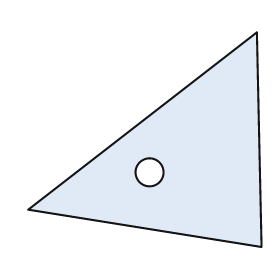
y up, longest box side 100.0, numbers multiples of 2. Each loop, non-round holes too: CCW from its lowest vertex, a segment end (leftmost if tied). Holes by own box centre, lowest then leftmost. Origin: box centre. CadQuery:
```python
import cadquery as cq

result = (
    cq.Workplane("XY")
    .moveTo(50.0, -46.0)
    .lineTo(48.0, 46.0)
    .lineTo(-50.0, -30.0)
    .close()
    .moveTo(2.0, -14.0)
    .circle(6.0)
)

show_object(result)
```